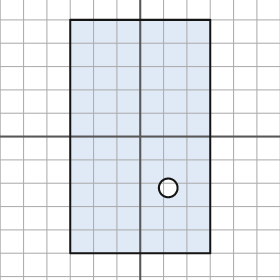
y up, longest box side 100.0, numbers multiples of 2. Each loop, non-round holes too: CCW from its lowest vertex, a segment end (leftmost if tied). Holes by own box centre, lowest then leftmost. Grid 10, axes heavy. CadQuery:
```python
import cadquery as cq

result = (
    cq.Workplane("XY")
    .moveTo(-30.0, -50.0)
    .lineTo(30.0, -50.0)
    .lineTo(30.0, 50.0)
    .lineTo(-30.0, 50.0)
    .close()
    .moveTo(12.0, -22.0)
    .circle(4.0)
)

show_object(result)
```